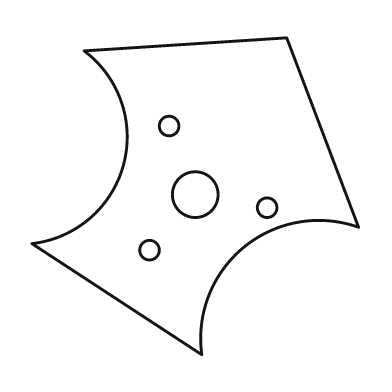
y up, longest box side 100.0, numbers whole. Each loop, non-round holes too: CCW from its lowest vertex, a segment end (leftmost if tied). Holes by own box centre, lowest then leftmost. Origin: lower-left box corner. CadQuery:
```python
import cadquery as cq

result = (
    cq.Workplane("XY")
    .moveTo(52.0, 0.0)
    .threePointArc((65.0, 33.0), (100.0, 39.0))
    .lineTo(78.0, 97.0)
    .lineTo(16.0, 93.0)
    .threePointArc((28.0, 58.0), (0.0, 34.0))
    .close()
    .moveTo(36.0, 32.0)
    .circle(3.0)
    .moveTo(72.0, 45.0)
    .circle(3.0)
    .moveTo(50.0, 49.0)
    .circle(7.0)
    .moveTo(42.0, 70.0)
    .circle(3.0)
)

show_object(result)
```